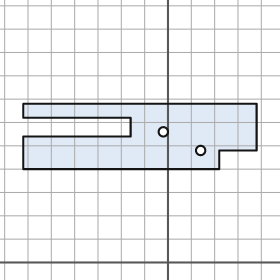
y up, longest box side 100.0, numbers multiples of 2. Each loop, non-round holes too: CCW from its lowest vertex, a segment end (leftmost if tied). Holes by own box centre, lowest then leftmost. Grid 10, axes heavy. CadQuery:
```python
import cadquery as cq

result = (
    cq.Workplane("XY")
    .moveTo(-62.0, 40.0)
    .lineTo(22.0, 40.0)
    .lineTo(22.0, 48.0)
    .lineTo(38.0, 48.0)
    .lineTo(38.0, 68.0)
    .lineTo(-62.0, 68.0)
    .lineTo(-62.0, 62.0)
    .lineTo(-16.0, 62.0)
    .lineTo(-16.0, 54.0)
    .lineTo(-62.0, 54.0)
    .close()
    .moveTo(14.0, 48.0)
    .circle(2.0)
    .moveTo(-2.0, 56.0)
    .circle(2.0)
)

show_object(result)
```